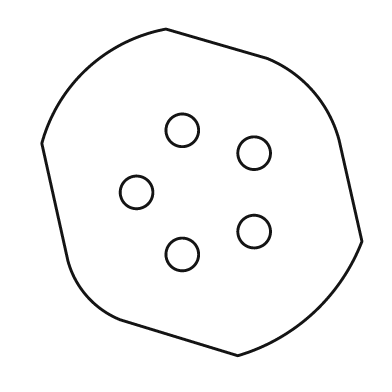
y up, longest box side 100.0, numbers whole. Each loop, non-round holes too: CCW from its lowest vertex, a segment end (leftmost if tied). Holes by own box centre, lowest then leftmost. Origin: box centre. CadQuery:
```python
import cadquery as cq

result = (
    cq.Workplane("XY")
    .moveTo(11.0, -50.0)
    .threePointArc((34.0, -37.0), (49.0, -15.0))
    .lineTo(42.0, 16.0)
    .threePointArc((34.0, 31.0), (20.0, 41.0))
    .lineTo(-11.0, 50.0)
    .threePointArc((-35.0, 38.0), (-49.0, 15.0))
    .lineTo(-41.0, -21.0)
    .threePointArc((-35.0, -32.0), (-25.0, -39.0))
    .close()
    .moveTo(-6.0, -19.0)
    .circle(5.0)
    .moveTo(16.0, -12.0)
    .circle(5.0)
    .moveTo(-20.0, 0.0)
    .circle(5.0)
    .moveTo(16.0, 12.0)
    .circle(5.0)
    .moveTo(-6.0, 19.0)
    .circle(5.0)
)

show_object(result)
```